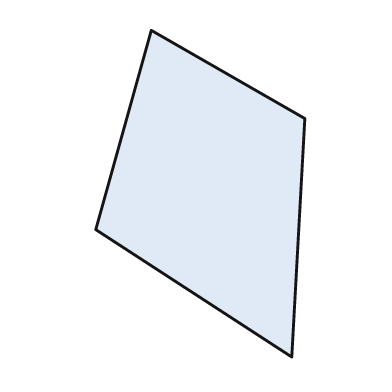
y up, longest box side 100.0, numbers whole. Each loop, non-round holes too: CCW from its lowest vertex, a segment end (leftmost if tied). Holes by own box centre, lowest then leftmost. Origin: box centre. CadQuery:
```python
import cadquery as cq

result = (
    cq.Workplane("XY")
    .moveTo(28.0, -50.0)
    .lineTo(32.0, 23.0)
    .lineTo(-15.0, 50.0)
    .lineTo(-32.0, -11.0)
    .close()
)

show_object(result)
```